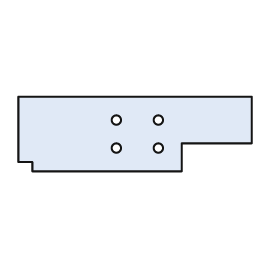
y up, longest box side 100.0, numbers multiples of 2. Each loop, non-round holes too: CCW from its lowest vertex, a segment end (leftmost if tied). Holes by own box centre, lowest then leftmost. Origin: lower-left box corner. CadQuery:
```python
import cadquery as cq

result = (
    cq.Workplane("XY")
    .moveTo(6.0, 0.0)
    .lineTo(70.0, 0.0)
    .lineTo(70.0, 12.0)
    .lineTo(100.0, 12.0)
    .lineTo(100.0, 32.0)
    .lineTo(0.0, 32.0)
    .lineTo(0.0, 4.0)
    .lineTo(6.0, 4.0)
    .close()
    .moveTo(42.0, 10.0)
    .circle(2.0)
    .moveTo(60.0, 10.0)
    .circle(2.0)
    .moveTo(42.0, 22.0)
    .circle(2.0)
    .moveTo(60.0, 22.0)
    .circle(2.0)
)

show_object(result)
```